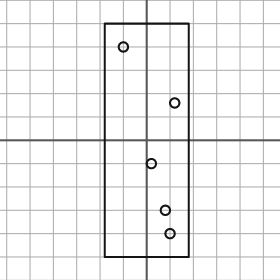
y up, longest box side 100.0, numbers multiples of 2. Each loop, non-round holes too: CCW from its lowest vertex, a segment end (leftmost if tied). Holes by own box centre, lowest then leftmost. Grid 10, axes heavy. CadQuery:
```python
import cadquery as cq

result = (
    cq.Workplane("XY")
    .moveTo(-18.0, -50.0)
    .lineTo(18.0, -50.0)
    .lineTo(18.0, 50.0)
    .lineTo(-18.0, 50.0)
    .close()
    .moveTo(10.0, -40.0)
    .circle(2.0)
    .moveTo(8.0, -30.0)
    .circle(2.0)
    .moveTo(2.0, -10.0)
    .circle(2.0)
    .moveTo(12.0, 16.0)
    .circle(2.0)
    .moveTo(-10.0, 40.0)
    .circle(2.0)
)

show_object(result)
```